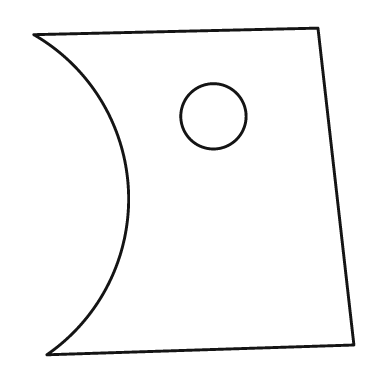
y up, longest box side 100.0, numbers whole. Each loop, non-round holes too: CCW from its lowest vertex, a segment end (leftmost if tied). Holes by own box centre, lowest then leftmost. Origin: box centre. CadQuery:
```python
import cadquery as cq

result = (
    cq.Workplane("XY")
    .moveTo(-45.0, -50.0)
    .lineTo(49.0, -47.0)
    .lineTo(38.0, 50.0)
    .lineTo(-49.0, 48.0)
    .threePointArc((-20.0, 0.0), (-45.0, -50.0))
    .close()
    .moveTo(6.0, 23.0)
    .circle(10.0)
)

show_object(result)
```